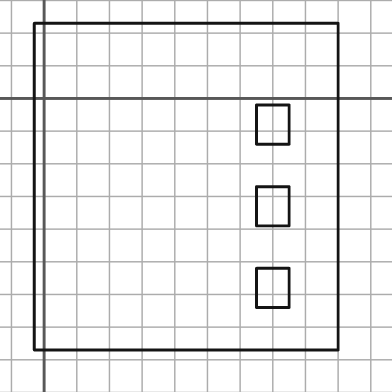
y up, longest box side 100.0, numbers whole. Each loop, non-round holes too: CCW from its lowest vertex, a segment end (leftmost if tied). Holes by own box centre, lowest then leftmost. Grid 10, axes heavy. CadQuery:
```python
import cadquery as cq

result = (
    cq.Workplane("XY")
    .moveTo(-3.0, -77.0)
    .lineTo(90.0, -77.0)
    .lineTo(90.0, 23.0)
    .lineTo(-3.0, 23.0)
    .close()
    .moveTo(65.0, -64.0)
    .lineTo(75.0, -64.0)
    .lineTo(75.0, -52.0)
    .lineTo(65.0, -52.0)
    .close()
    .moveTo(65.0, -39.0)
    .lineTo(75.0, -39.0)
    .lineTo(75.0, -27.0)
    .lineTo(65.0, -27.0)
    .close()
    .moveTo(65.0, -14.0)
    .lineTo(75.0, -14.0)
    .lineTo(75.0, -2.0)
    .lineTo(65.0, -2.0)
    .close()
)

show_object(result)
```